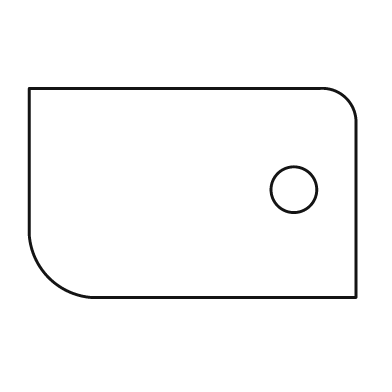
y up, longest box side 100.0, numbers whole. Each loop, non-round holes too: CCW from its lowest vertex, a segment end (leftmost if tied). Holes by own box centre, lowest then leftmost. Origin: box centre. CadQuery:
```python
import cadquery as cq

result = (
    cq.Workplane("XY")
    .moveTo(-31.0, -32.0)
    .lineTo(50.0, -32.0)
    .lineTo(50.0, 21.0)
    .threePointArc((47.0, 29.0), (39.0, 32.0))
    .lineTo(-50.0, 32.0)
    .lineTo(-50.0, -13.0)
    .threePointArc((-44.0, -26.0), (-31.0, -32.0))
    .close()
    .moveTo(31.0, 1.0)
    .circle(7.0)
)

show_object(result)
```